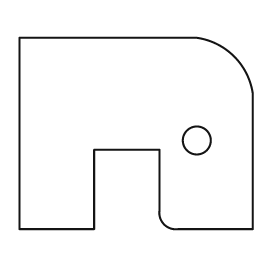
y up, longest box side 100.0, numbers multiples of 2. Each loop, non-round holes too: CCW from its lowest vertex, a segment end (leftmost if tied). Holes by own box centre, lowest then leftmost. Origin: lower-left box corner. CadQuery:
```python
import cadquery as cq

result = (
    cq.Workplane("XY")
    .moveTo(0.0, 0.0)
    .lineTo(32.0, 0.0)
    .lineTo(32.0, 34.0)
    .lineTo(60.0, 34.0)
    .lineTo(60.0, 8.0)
    .threePointArc((62.0, 2.0), (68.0, 0.0))
    .lineTo(100.0, 0.0)
    .lineTo(100.0, 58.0)
    .threePointArc((92.0, 74.0), (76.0, 82.0))
    .lineTo(0.0, 82.0)
    .close()
    .moveTo(76.0, 38.0)
    .circle(6.0)
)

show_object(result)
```